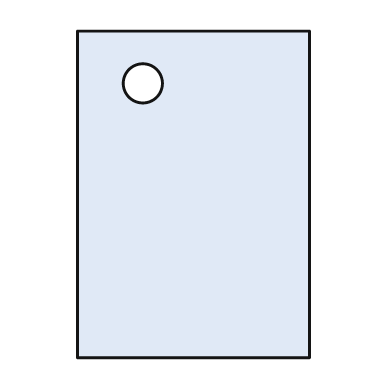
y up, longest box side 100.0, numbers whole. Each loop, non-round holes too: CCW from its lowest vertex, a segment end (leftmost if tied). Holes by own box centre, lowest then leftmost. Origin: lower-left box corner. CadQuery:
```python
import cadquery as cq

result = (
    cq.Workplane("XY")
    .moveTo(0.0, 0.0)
    .lineTo(71.0, 0.0)
    .lineTo(71.0, 100.0)
    .lineTo(0.0, 100.0)
    .close()
    .moveTo(20.0, 84.0)
    .circle(6.0)
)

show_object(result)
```